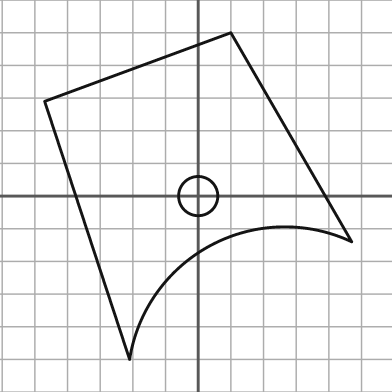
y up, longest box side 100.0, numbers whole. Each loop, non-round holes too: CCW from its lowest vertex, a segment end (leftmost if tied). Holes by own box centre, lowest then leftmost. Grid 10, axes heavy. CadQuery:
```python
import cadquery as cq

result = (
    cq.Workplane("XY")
    .moveTo(-21.0, -50.0)
    .threePointArc((4.0, -15.0), (47.0, -14.0))
    .lineTo(10.0, 50.0)
    .lineTo(-47.0, 29.0)
    .close()
    .moveTo(0.0, 0.0)
    .circle(6.0)
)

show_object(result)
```